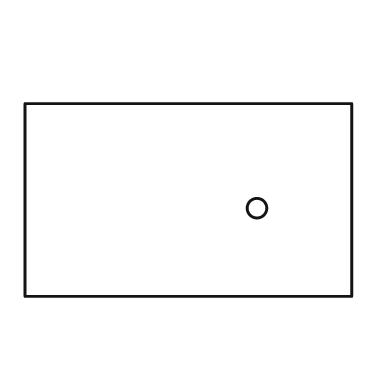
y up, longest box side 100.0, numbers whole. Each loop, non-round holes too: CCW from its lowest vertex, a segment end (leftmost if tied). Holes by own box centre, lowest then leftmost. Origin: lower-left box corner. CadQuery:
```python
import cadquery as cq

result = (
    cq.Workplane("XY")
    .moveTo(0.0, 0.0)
    .lineTo(100.0, 0.0)
    .lineTo(100.0, 59.0)
    .lineTo(0.0, 59.0)
    .close()
    .moveTo(71.0, 27.0)
    .circle(3.0)
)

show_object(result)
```